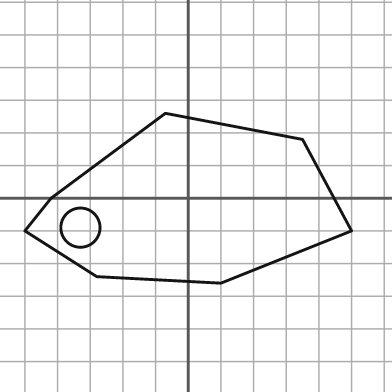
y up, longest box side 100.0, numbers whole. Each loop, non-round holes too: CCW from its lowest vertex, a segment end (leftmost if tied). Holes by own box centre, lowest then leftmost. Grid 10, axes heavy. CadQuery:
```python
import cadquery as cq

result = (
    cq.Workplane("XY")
    .moveTo(10.0, -26.0)
    .lineTo(50.0, -10.0)
    .lineTo(35.0, 18.0)
    .lineTo(-7.0, 26.0)
    .lineTo(-42.0, 0.0)
    .lineTo(-50.0, -10.0)
    .lineTo(-28.0, -24.0)
    .close()
    .moveTo(-33.0, -9.0)
    .circle(6.0)
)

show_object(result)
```